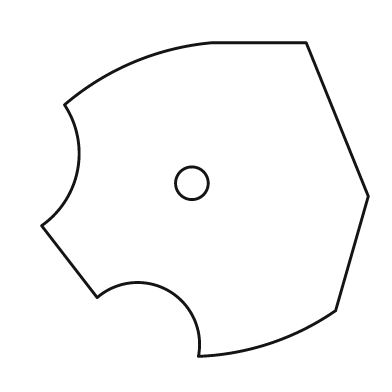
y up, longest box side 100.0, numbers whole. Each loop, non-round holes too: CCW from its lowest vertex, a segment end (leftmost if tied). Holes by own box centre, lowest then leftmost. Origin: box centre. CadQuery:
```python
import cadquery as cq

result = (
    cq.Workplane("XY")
    .moveTo(-2.0, -48.0)
    .threePointArc((20.0, -44.0), (40.0, -34.0))
    .lineTo(50.0, 1.0)
    .lineTo(31.0, 48.0)
    .lineTo(2.0, 48.0)
    .threePointArc((-22.0, 42.0), (-43.0, 29.0))
    .threePointArc((-39.0, 9.0), (-50.0, -8.0))
    .lineTo(-33.0, -30.0)
    .threePointArc((-11.0, -28.0), (-2.0, -48.0))
    .close()
    .moveTo(-4.0, 5.0)
    .circle(5.0)
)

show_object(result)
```